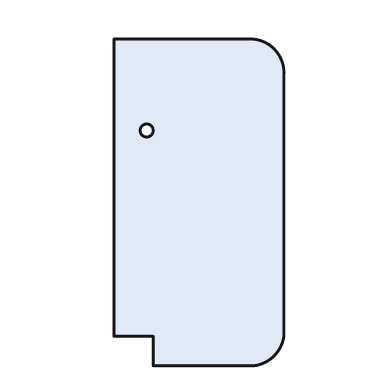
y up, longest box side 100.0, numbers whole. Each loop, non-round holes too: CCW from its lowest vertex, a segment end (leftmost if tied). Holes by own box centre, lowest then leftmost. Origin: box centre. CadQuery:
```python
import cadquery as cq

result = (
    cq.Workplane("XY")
    .moveTo(-14.0, -50.0)
    .lineTo(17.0, -50.0)
    .threePointArc((23.0, -47.0), (26.0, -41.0))
    .lineTo(26.0, 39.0)
    .threePointArc((23.0, 47.0), (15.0, 50.0))
    .lineTo(-26.0, 50.0)
    .lineTo(-26.0, -41.0)
    .lineTo(-14.0, -41.0)
    .close()
    .moveTo(-16.0, 22.0)
    .circle(2.0)
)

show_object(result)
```